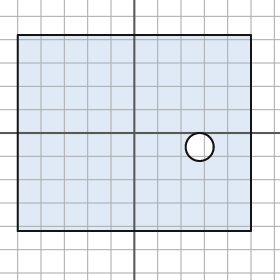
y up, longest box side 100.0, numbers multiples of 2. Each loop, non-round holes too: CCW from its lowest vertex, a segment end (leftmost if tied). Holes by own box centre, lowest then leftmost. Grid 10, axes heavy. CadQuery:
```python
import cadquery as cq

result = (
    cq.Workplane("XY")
    .moveTo(-50.0, -42.0)
    .lineTo(50.0, -42.0)
    .lineTo(50.0, 42.0)
    .lineTo(-50.0, 42.0)
    .close()
    .moveTo(28.0, -6.0)
    .circle(6.0)
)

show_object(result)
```